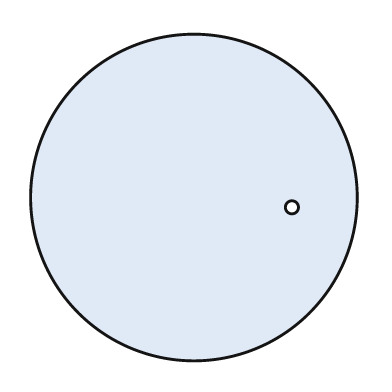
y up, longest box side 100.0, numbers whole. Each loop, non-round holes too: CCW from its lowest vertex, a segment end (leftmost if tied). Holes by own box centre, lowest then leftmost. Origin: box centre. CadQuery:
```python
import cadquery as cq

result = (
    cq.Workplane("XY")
    .moveTo(0.0, 0.0)
    .circle(50.0)
    .moveTo(30.0, -3.0)
    .circle(2.0)
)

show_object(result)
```